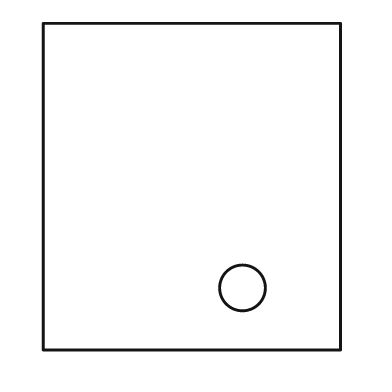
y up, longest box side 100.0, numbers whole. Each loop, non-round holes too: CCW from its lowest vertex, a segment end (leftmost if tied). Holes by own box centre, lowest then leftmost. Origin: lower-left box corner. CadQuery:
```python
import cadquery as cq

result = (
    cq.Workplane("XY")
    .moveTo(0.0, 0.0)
    .lineTo(91.0, 0.0)
    .lineTo(91.0, 100.0)
    .lineTo(0.0, 100.0)
    .close()
    .moveTo(61.0, 19.0)
    .circle(7.0)
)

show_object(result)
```